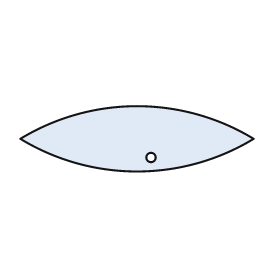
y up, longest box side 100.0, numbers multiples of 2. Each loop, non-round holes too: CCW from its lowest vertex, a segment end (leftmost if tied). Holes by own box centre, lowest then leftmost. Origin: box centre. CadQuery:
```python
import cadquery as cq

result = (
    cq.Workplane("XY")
    .moveTo(-50.0, 0.0)
    .threePointArc((0.0, -14.0), (50.0, 0.0))
    .threePointArc((0.0, 14.0), (-50.0, 0.0))
    .close()
    .moveTo(6.0, -8.0)
    .circle(2.0)
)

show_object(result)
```